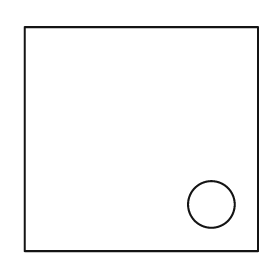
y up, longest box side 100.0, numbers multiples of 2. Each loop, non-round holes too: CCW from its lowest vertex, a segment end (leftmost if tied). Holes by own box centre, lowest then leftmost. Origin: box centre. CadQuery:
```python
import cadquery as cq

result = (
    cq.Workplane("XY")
    .moveTo(-50.0, -48.0)
    .lineTo(50.0, -48.0)
    .lineTo(50.0, 48.0)
    .lineTo(-50.0, 48.0)
    .close()
    .moveTo(30.0, -28.0)
    .circle(10.0)
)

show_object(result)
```